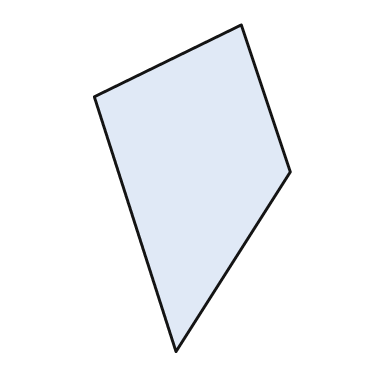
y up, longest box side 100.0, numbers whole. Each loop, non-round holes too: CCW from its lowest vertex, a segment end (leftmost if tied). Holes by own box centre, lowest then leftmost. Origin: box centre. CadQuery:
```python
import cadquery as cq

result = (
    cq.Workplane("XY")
    .moveTo(-5.0, -50.0)
    .lineTo(30.0, 5.0)
    .lineTo(15.0, 50.0)
    .lineTo(-30.0, 28.0)
    .close()
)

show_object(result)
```